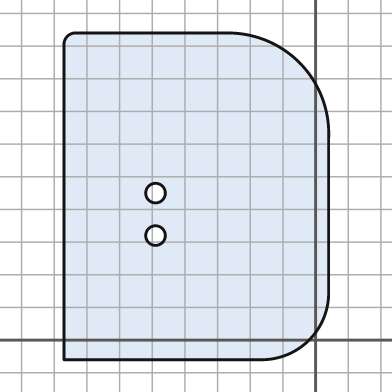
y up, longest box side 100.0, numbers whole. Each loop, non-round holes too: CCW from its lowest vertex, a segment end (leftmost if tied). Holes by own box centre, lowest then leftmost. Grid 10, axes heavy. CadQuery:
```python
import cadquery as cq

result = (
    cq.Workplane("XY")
    .moveTo(-77.0, -6.0)
    .lineTo(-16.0, -6.0)
    .threePointArc((-2.0, 0.0), (4.0, 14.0))
    .lineTo(4.0, 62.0)
    .threePointArc((-5.0, 85.0), (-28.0, 94.0))
    .lineTo(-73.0, 94.0)
    .threePointArc((-76.0, 93.0), (-77.0, 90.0))
    .close()
    .moveTo(-49.0, 32.0)
    .circle(3.0)
    .moveTo(-49.0, 45.0)
    .circle(3.0)
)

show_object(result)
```